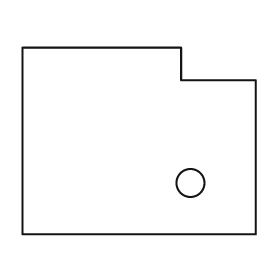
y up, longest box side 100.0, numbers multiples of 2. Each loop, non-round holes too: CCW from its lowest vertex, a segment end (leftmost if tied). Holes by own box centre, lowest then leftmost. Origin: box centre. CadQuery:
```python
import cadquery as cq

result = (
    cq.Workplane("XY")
    .moveTo(-50.0, -40.0)
    .lineTo(50.0, -40.0)
    .lineTo(50.0, 26.0)
    .lineTo(18.0, 26.0)
    .lineTo(18.0, 40.0)
    .lineTo(-50.0, 40.0)
    .close()
    .moveTo(22.0, -18.0)
    .circle(6.0)
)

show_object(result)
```